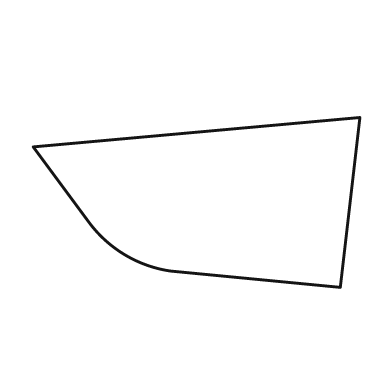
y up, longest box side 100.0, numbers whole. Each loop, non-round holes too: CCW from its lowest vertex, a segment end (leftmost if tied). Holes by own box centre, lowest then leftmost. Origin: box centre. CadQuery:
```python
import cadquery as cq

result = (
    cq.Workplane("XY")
    .moveTo(44.0, -26.0)
    .lineTo(50.0, 26.0)
    .lineTo(-50.0, 17.0)
    .lineTo(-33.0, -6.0)
    .threePointArc((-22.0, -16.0), (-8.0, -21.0))
    .close()
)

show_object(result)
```